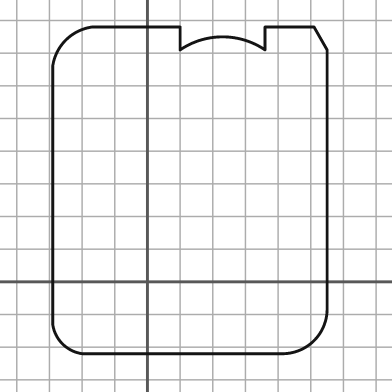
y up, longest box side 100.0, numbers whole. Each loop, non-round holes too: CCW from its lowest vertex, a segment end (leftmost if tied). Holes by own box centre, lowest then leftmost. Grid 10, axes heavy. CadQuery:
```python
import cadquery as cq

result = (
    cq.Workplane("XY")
    .moveTo(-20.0, -22.0)
    .lineTo(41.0, -22.0)
    .threePointArc((51.0, -18.0), (55.0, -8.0))
    .lineTo(55.0, 71.0)
    .lineTo(51.0, 78.0)
    .lineTo(36.0, 78.0)
    .lineTo(36.0, 71.0)
    .threePointArc((23.0, 75.0), (10.0, 71.0))
    .lineTo(10.0, 78.0)
    .lineTo(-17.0, 78.0)
    .threePointArc((-25.0, 74.0), (-29.0, 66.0))
    .lineTo(-29.0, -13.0)
    .threePointArc((-26.0, -19.0), (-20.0, -22.0))
    .close()
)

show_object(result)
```